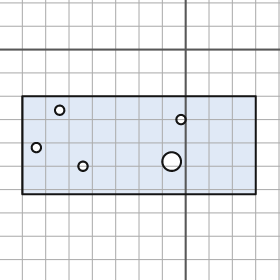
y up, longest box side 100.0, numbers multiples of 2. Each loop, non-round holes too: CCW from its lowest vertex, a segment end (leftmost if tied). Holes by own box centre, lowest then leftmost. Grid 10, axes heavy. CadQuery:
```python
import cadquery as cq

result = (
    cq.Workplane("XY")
    .moveTo(-70.0, -62.0)
    .lineTo(30.0, -62.0)
    .lineTo(30.0, -20.0)
    .lineTo(-70.0, -20.0)
    .close()
    .moveTo(-44.0, -50.0)
    .circle(2.0)
    .moveTo(-6.0, -48.0)
    .circle(4.0)
    .moveTo(-64.0, -42.0)
    .circle(2.0)
    .moveTo(-2.0, -30.0)
    .circle(2.0)
    .moveTo(-54.0, -26.0)
    .circle(2.0)
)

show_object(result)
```